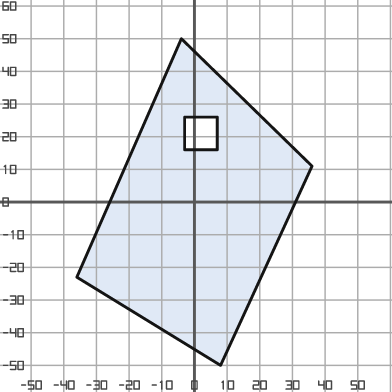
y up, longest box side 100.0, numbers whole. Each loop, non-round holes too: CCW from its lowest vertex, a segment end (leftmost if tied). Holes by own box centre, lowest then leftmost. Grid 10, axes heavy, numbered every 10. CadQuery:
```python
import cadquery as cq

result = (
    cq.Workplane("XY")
    .moveTo(8.0, -50.0)
    .lineTo(36.0, 11.0)
    .lineTo(-4.0, 50.0)
    .lineTo(-36.0, -23.0)
    .close()
    .moveTo(-3.0, 16.0)
    .lineTo(7.0, 16.0)
    .lineTo(7.0, 26.0)
    .lineTo(-3.0, 26.0)
    .close()
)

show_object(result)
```